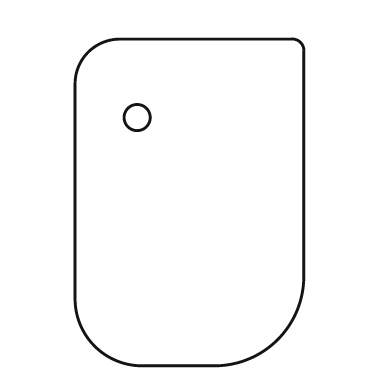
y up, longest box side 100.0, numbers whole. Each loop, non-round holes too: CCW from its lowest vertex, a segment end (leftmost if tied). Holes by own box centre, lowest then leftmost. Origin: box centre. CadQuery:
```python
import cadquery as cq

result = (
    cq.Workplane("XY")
    .moveTo(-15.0, -50.0)
    .lineTo(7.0, -50.0)
    .threePointArc((27.0, -42.0), (35.0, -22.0))
    .lineTo(35.0, 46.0)
    .threePointArc((34.0, 49.0), (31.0, 50.0))
    .lineTo(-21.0, 50.0)
    .threePointArc((-31.0, 46.0), (-35.0, 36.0))
    .lineTo(-35.0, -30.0)
    .threePointArc((-29.0, -44.0), (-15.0, -50.0))
    .close()
    .moveTo(-16.0, 26.0)
    .circle(4.0)
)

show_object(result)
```